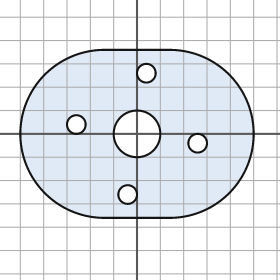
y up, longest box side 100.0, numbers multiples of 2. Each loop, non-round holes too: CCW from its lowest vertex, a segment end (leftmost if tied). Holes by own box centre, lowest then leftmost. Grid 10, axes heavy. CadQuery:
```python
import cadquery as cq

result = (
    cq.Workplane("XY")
    .moveTo(-14.0, -36.0)
    .lineTo(14.0, -36.0)
    .threePointArc((50.0, 0.0), (14.0, 36.0))
    .lineTo(-14.0, 36.0)
    .threePointArc((-50.0, 0.0), (-14.0, -36.0))
    .close()
    .moveTo(-4.0, -26.0)
    .circle(4.0)
    .moveTo(26.0, -4.0)
    .circle(4.0)
    .moveTo(0.0, 0.0)
    .circle(10.0)
    .moveTo(-26.0, 4.0)
    .circle(4.0)
    .moveTo(4.0, 26.0)
    .circle(4.0)
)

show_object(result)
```